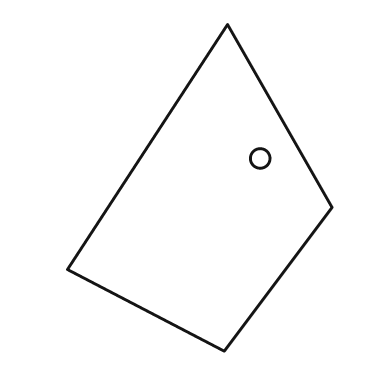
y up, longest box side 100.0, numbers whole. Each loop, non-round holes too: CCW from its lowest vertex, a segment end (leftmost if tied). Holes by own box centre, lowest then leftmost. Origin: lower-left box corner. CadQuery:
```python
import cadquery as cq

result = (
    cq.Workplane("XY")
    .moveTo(48.0, 0.0)
    .lineTo(81.0, 44.0)
    .lineTo(49.0, 100.0)
    .lineTo(0.0, 25.0)
    .close()
    .moveTo(59.0, 59.0)
    .circle(3.0)
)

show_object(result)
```